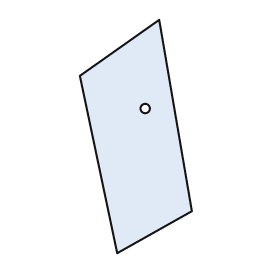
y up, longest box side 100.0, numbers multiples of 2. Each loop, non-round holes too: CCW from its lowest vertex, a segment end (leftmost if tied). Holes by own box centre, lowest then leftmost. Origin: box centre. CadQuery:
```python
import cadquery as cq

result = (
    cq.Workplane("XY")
    .moveTo(-8.0, -50.0)
    .lineTo(24.0, -32.0)
    .lineTo(10.0, 50.0)
    .lineTo(-24.0, 26.0)
    .close()
    .moveTo(4.0, 12.0)
    .circle(2.0)
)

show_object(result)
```